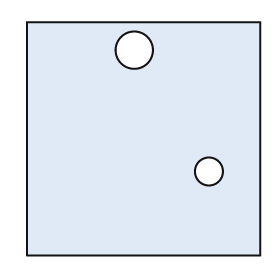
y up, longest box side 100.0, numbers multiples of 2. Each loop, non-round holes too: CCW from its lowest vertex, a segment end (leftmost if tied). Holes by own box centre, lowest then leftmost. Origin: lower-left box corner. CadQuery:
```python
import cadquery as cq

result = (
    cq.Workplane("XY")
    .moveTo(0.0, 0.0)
    .lineTo(100.0, 0.0)
    .lineTo(100.0, 100.0)
    .lineTo(0.0, 100.0)
    .close()
    .moveTo(78.0, 36.0)
    .circle(6.0)
    .moveTo(46.0, 88.0)
    .circle(8.0)
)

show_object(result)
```